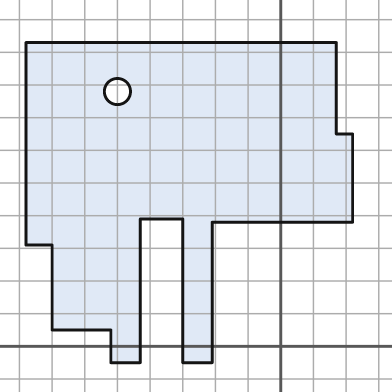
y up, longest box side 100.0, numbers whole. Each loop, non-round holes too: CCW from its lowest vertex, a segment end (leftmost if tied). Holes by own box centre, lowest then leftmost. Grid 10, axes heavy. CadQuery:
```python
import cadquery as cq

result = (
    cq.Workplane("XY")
    .moveTo(-52.0, -5.0)
    .lineTo(-43.0, -5.0)
    .lineTo(-43.0, 39.0)
    .lineTo(-30.0, 39.0)
    .lineTo(-30.0, -5.0)
    .lineTo(-21.0, -5.0)
    .lineTo(-21.0, 38.0)
    .lineTo(22.0, 38.0)
    .lineTo(22.0, 65.0)
    .lineTo(17.0, 65.0)
    .lineTo(17.0, 93.0)
    .lineTo(-78.0, 93.0)
    .lineTo(-78.0, 31.0)
    .lineTo(-70.0, 31.0)
    .lineTo(-70.0, 5.0)
    .lineTo(-52.0, 5.0)
    .close()
    .moveTo(-50.0, 78.0)
    .circle(4.0)
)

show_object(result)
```